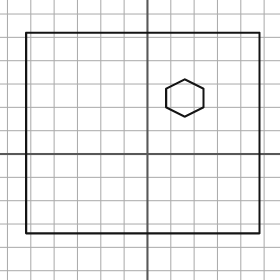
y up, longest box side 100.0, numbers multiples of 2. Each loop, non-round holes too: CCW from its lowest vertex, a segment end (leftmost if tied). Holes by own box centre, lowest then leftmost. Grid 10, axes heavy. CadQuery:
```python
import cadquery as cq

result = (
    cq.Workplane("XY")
    .moveTo(-52.0, -34.0)
    .lineTo(48.0, -34.0)
    .lineTo(48.0, 52.0)
    .lineTo(-52.0, 52.0)
    .close()
    .moveTo(16.0, 16.0)
    .lineTo(24.0, 20.0)
    .lineTo(24.0, 28.0)
    .lineTo(16.0, 32.0)
    .lineTo(8.0, 28.0)
    .lineTo(8.0, 20.0)
    .close()
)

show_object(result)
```